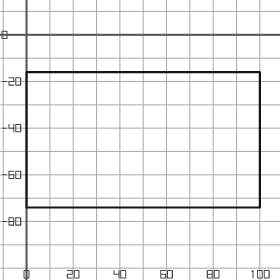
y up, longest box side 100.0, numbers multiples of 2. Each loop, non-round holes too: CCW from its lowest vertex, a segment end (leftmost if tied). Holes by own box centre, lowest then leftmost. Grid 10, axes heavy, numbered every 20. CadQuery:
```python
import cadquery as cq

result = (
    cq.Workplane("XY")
    .moveTo(0.0, -74.0)
    .lineTo(100.0, -74.0)
    .lineTo(100.0, -16.0)
    .lineTo(0.0, -16.0)
    .close()
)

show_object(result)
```